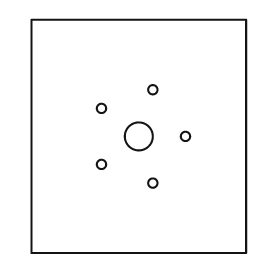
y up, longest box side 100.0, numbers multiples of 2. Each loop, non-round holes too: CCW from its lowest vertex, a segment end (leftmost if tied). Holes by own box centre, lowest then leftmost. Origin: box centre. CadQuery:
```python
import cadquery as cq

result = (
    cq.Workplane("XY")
    .moveTo(-46.0, -50.0)
    .lineTo(46.0, -50.0)
    .lineTo(46.0, 50.0)
    .lineTo(-46.0, 50.0)
    .close()
    .moveTo(6.0, -20.0)
    .circle(2.0)
    .moveTo(-16.0, -12.0)
    .circle(2.0)
    .moveTo(0.0, 0.0)
    .circle(6.0)
    .moveTo(20.0, 0.0)
    .circle(2.0)
    .moveTo(-16.0, 12.0)
    .circle(2.0)
    .moveTo(6.0, 20.0)
    .circle(2.0)
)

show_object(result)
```